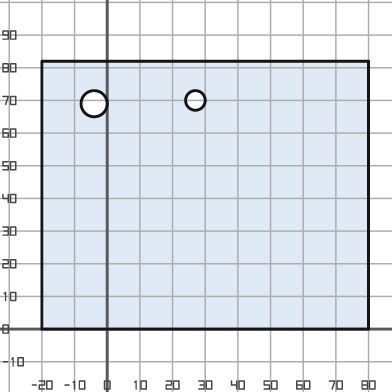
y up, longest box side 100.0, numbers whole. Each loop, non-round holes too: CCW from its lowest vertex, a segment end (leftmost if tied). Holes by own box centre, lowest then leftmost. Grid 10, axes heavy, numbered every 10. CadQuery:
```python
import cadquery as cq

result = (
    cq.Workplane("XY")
    .moveTo(-20.0, 0.0)
    .lineTo(80.0, 0.0)
    .lineTo(80.0, 82.0)
    .lineTo(-20.0, 82.0)
    .close()
    .moveTo(-4.0, 69.0)
    .circle(4.0)
    .moveTo(27.0, 70.0)
    .circle(3.0)
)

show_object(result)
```